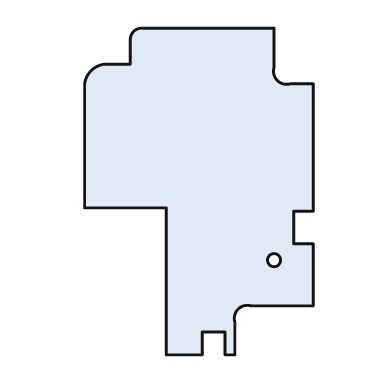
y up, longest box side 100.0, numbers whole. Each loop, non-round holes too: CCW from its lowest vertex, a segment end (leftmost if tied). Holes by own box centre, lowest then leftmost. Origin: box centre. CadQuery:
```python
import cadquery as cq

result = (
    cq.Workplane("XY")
    .moveTo(-10.0, -50.0)
    .lineTo(1.0, -50.0)
    .lineTo(1.0, -43.0)
    .lineTo(8.0, -43.0)
    .lineTo(8.0, -50.0)
    .lineTo(11.0, -50.0)
    .lineTo(11.0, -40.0)
    .threePointArc((12.0, -36.0), (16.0, -35.0))
    .lineTo(35.0, -35.0)
    .lineTo(35.0, -16.0)
    .lineTo(29.0, -16.0)
    .lineTo(29.0, -6.0)
    .lineTo(35.0, -6.0)
    .lineTo(35.0, 33.0)
    .lineTo(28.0, 33.0)
    .threePointArc((24.0, 34.0), (23.0, 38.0))
    .lineTo(23.0, 50.0)
    .lineTo(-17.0, 50.0)
    .threePointArc((-20.0, 49.0), (-21.0, 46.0))
    .lineTo(-21.0, 39.0)
    .lineTo(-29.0, 39.0)
    .threePointArc((-33.0, 37.0), (-35.0, 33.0))
    .lineTo(-35.0, -5.0)
    .lineTo(-10.0, -5.0)
    .close()
    .moveTo(23.0, -21.0)
    .circle(2.0)
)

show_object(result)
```